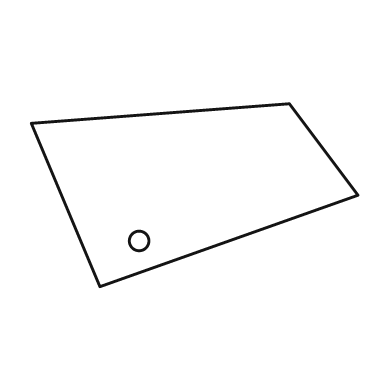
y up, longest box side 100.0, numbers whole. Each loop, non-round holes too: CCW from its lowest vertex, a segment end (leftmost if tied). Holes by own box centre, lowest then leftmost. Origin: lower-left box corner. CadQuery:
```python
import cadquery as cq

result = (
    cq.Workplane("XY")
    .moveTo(21.0, 0.0)
    .lineTo(100.0, 28.0)
    .lineTo(79.0, 56.0)
    .lineTo(0.0, 50.0)
    .close()
    .moveTo(33.0, 14.0)
    .circle(3.0)
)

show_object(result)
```